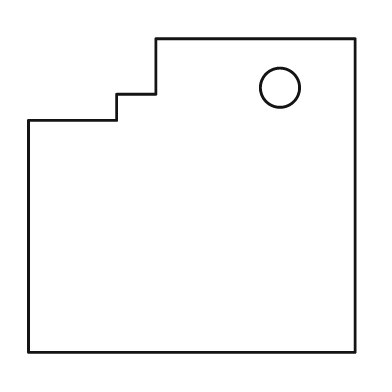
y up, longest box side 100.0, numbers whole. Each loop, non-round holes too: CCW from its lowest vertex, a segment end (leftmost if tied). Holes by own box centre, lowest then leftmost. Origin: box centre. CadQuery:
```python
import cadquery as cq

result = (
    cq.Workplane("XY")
    .moveTo(-50.0, -48.0)
    .lineTo(50.0, -48.0)
    .lineTo(50.0, 48.0)
    .lineTo(-11.0, 48.0)
    .lineTo(-11.0, 31.0)
    .lineTo(-23.0, 31.0)
    .lineTo(-23.0, 23.0)
    .lineTo(-50.0, 23.0)
    .close()
    .moveTo(27.0, 33.0)
    .circle(6.0)
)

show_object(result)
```